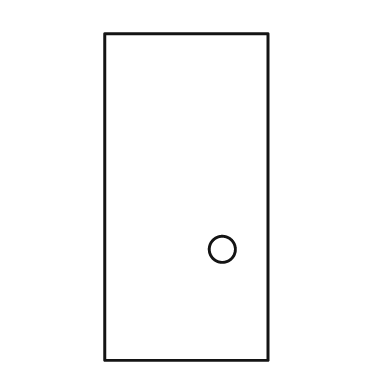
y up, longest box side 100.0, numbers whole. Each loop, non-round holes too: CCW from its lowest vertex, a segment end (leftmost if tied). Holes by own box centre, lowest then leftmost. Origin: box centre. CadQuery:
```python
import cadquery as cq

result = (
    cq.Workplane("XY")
    .moveTo(-25.0, -50.0)
    .lineTo(25.0, -50.0)
    .lineTo(25.0, 50.0)
    .lineTo(-25.0, 50.0)
    .close()
    .moveTo(11.0, -16.0)
    .circle(4.0)
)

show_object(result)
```